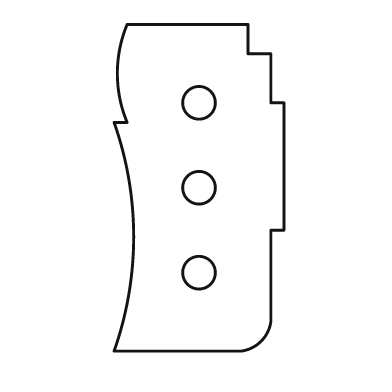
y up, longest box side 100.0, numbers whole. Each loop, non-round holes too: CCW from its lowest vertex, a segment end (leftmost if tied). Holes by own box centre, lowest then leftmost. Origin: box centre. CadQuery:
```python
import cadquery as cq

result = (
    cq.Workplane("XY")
    .moveTo(-26.0, -50.0)
    .lineTo(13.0, -50.0)
    .threePointArc((19.0, -47.0), (22.0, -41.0))
    .lineTo(22.0, -13.0)
    .lineTo(26.0, -13.0)
    .lineTo(26.0, 26.0)
    .lineTo(22.0, 26.0)
    .lineTo(22.0, 41.0)
    .lineTo(15.0, 41.0)
    .lineTo(15.0, 50.0)
    .lineTo(-22.0, 50.0)
    .threePointArc((-25.0, 35.0), (-22.0, 20.0))
    .lineTo(-26.0, 20.0)
    .threePointArc((-20.0, -15.0), (-26.0, -50.0))
    .close()
    .moveTo(0.0, -26.0)
    .circle(5.0)
    .moveTo(0.0, 0.0)
    .circle(5.0)
    .moveTo(0.0, 26.0)
    .circle(5.0)
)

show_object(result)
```